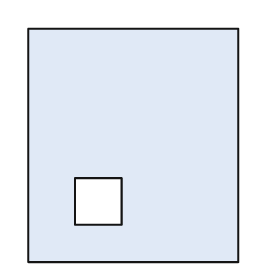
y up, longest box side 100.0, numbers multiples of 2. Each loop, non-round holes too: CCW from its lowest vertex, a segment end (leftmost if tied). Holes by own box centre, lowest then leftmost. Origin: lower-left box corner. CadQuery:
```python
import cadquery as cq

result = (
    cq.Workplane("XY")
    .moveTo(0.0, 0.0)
    .lineTo(90.0, 0.0)
    .lineTo(90.0, 100.0)
    .lineTo(0.0, 100.0)
    .close()
    .moveTo(20.0, 16.0)
    .lineTo(40.0, 16.0)
    .lineTo(40.0, 36.0)
    .lineTo(20.0, 36.0)
    .close()
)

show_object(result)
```